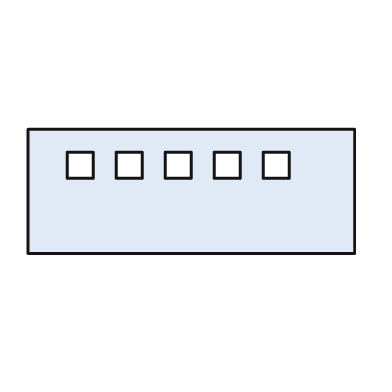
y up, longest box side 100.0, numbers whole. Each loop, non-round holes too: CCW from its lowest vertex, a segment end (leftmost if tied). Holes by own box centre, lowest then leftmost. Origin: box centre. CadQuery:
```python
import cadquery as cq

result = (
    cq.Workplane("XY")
    .moveTo(-50.0, -19.0)
    .lineTo(50.0, -19.0)
    .lineTo(50.0, 19.0)
    .lineTo(-50.0, 19.0)
    .close()
    .moveTo(-38.0, 4.0)
    .lineTo(-30.0, 4.0)
    .lineTo(-30.0, 12.0)
    .lineTo(-38.0, 12.0)
    .close()
    .moveTo(-23.0, 4.0)
    .lineTo(-15.0, 4.0)
    .lineTo(-15.0, 12.0)
    .lineTo(-23.0, 12.0)
    .close()
    .moveTo(-8.0, 4.0)
    .lineTo(0.0, 4.0)
    .lineTo(0.0, 12.0)
    .lineTo(-8.0, 12.0)
    .close()
    .moveTo(7.0, 4.0)
    .lineTo(15.0, 4.0)
    .lineTo(15.0, 12.0)
    .lineTo(7.0, 12.0)
    .close()
    .moveTo(22.0, 4.0)
    .lineTo(30.0, 4.0)
    .lineTo(30.0, 12.0)
    .lineTo(22.0, 12.0)
    .close()
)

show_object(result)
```